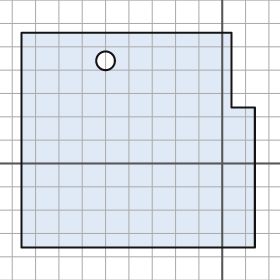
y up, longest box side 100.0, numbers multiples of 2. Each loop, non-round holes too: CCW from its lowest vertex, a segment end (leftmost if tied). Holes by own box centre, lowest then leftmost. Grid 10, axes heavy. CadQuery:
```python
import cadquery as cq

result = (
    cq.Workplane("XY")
    .moveTo(-86.0, -36.0)
    .lineTo(14.0, -36.0)
    .lineTo(14.0, 24.0)
    .lineTo(4.0, 24.0)
    .lineTo(4.0, 56.0)
    .lineTo(-86.0, 56.0)
    .close()
    .moveTo(-50.0, 44.0)
    .circle(4.0)
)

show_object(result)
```